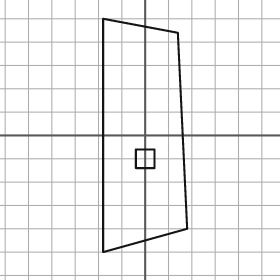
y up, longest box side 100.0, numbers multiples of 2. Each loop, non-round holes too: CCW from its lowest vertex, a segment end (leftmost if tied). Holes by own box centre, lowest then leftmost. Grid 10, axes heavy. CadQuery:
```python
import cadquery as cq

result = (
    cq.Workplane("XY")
    .moveTo(-18.0, -50.0)
    .lineTo(18.0, -40.0)
    .lineTo(14.0, 44.0)
    .lineTo(-18.0, 50.0)
    .close()
    .moveTo(-4.0, -14.0)
    .lineTo(4.0, -14.0)
    .lineTo(4.0, -6.0)
    .lineTo(-4.0, -6.0)
    .close()
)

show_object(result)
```